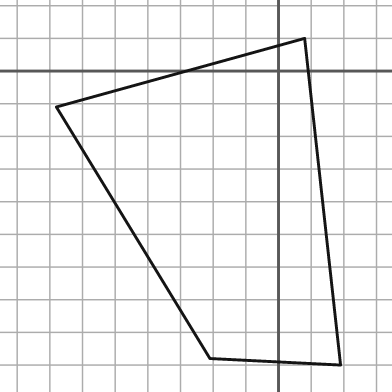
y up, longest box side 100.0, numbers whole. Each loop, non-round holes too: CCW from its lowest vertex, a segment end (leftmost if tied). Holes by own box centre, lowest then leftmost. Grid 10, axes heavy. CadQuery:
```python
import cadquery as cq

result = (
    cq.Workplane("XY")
    .moveTo(19.0, -90.0)
    .lineTo(8.0, 10.0)
    .lineTo(-68.0, -11.0)
    .lineTo(-21.0, -88.0)
    .close()
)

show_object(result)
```